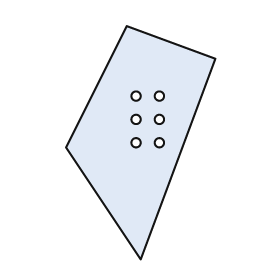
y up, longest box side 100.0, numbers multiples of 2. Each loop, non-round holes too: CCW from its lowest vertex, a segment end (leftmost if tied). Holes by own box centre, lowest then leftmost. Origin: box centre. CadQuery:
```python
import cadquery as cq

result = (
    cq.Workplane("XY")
    .moveTo(0.0, -50.0)
    .lineTo(32.0, 36.0)
    .lineTo(-6.0, 50.0)
    .lineTo(-32.0, -2.0)
    .close()
    .moveTo(-2.0, 0.0)
    .circle(2.0)
    .moveTo(8.0, 0.0)
    .circle(2.0)
    .moveTo(-2.0, 10.0)
    .circle(2.0)
    .moveTo(8.0, 10.0)
    .circle(2.0)
    .moveTo(-2.0, 20.0)
    .circle(2.0)
    .moveTo(8.0, 20.0)
    .circle(2.0)
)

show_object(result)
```